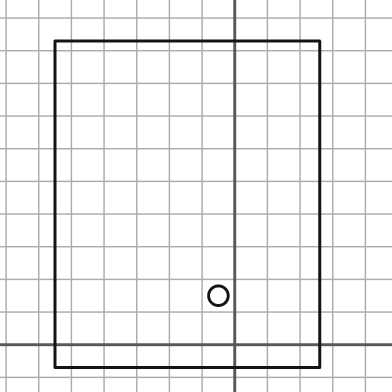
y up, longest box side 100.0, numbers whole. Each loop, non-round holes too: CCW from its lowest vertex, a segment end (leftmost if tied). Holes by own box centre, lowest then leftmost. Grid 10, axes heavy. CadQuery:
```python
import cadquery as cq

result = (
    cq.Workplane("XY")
    .moveTo(-55.0, -7.0)
    .lineTo(26.0, -7.0)
    .lineTo(26.0, 93.0)
    .lineTo(-55.0, 93.0)
    .close()
    .moveTo(-5.0, 15.0)
    .circle(3.0)
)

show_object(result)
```